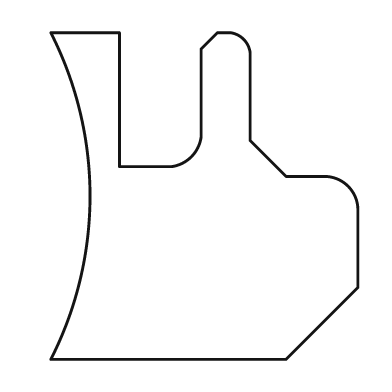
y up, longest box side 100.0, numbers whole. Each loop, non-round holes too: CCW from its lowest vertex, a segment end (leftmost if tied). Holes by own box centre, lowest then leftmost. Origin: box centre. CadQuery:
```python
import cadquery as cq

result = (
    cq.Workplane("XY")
    .moveTo(-47.0, -50.0)
    .lineTo(25.0, -50.0)
    .lineTo(47.0, -28.0)
    .lineTo(47.0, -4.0)
    .threePointArc((44.0, 3.0), (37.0, 6.0))
    .lineTo(25.0, 6.0)
    .lineTo(14.0, 17.0)
    .lineTo(14.0, 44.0)
    .threePointArc((12.0, 48.0), (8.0, 50.0))
    .lineTo(4.0, 50.0)
    .lineTo(-1.0, 45.0)
    .lineTo(-1.0, 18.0)
    .threePointArc((-4.0, 12.0), (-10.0, 9.0))
    .lineTo(-26.0, 9.0)
    .lineTo(-26.0, 50.0)
    .lineTo(-47.0, 50.0)
    .threePointArc((-35.0, 0.0), (-47.0, -50.0))
    .close()
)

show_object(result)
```